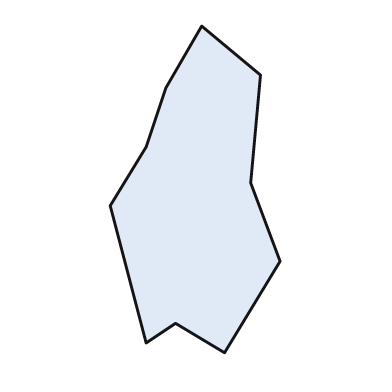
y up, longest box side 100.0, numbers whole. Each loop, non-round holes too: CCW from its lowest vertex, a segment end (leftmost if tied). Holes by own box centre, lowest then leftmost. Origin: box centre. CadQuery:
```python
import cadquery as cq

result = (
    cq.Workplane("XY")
    .moveTo(9.0, -50.0)
    .lineTo(26.0, -22.0)
    .lineTo(17.0, 2.0)
    .lineTo(20.0, 35.0)
    .lineTo(2.0, 50.0)
    .lineTo(-9.0, 31.0)
    .lineTo(-15.0, 13.0)
    .lineTo(-26.0, -5.0)
    .lineTo(-15.0, -47.0)
    .lineTo(-6.0, -41.0)
    .close()
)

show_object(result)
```